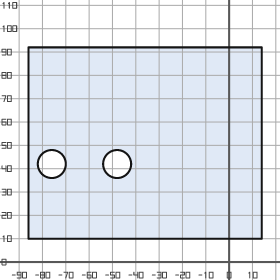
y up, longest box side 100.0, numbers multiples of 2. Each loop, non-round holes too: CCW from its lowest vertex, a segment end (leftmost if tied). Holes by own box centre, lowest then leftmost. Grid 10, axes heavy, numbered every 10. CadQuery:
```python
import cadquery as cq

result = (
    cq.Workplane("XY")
    .moveTo(-86.0, 10.0)
    .lineTo(14.0, 10.0)
    .lineTo(14.0, 92.0)
    .lineTo(-86.0, 92.0)
    .close()
    .moveTo(-76.0, 42.0)
    .circle(6.0)
    .moveTo(-48.0, 42.0)
    .circle(6.0)
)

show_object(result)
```